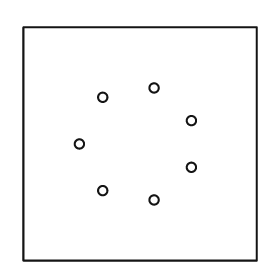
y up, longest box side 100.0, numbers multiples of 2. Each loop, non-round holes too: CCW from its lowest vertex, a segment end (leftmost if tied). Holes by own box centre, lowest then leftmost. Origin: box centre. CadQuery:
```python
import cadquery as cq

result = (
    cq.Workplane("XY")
    .moveTo(-50.0, -50.0)
    .lineTo(50.0, -50.0)
    .lineTo(50.0, 50.0)
    .lineTo(-50.0, 50.0)
    .close()
    .moveTo(6.0, -24.0)
    .circle(2.0)
    .moveTo(-16.0, -20.0)
    .circle(2.0)
    .moveTo(22.0, -10.0)
    .circle(2.0)
    .moveTo(-26.0, 0.0)
    .circle(2.0)
    .moveTo(22.0, 10.0)
    .circle(2.0)
    .moveTo(-16.0, 20.0)
    .circle(2.0)
    .moveTo(6.0, 24.0)
    .circle(2.0)
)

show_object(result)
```